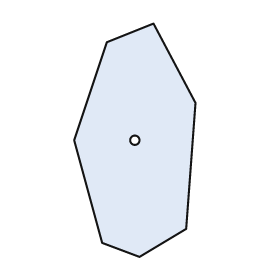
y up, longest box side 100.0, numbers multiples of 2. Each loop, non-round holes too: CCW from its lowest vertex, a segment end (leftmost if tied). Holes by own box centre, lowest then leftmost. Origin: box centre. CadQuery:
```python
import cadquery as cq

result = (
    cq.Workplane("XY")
    .moveTo(2.0, -50.0)
    .lineTo(22.0, -38.0)
    .lineTo(26.0, 16.0)
    .lineTo(8.0, 50.0)
    .lineTo(-12.0, 42.0)
    .lineTo(-26.0, 0.0)
    .lineTo(-14.0, -44.0)
    .close()
    .moveTo(0.0, 0.0)
    .circle(2.0)
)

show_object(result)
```